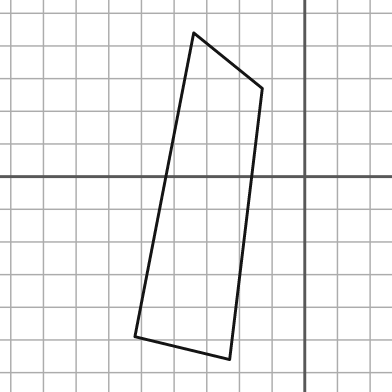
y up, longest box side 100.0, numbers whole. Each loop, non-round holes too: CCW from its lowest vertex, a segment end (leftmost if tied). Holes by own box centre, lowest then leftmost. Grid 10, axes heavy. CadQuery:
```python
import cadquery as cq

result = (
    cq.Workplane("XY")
    .moveTo(-23.0, -56.0)
    .lineTo(-13.0, 27.0)
    .lineTo(-34.0, 44.0)
    .lineTo(-52.0, -49.0)
    .close()
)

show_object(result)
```